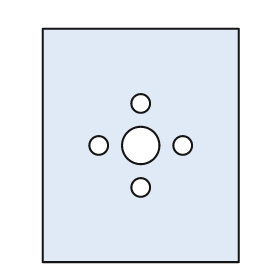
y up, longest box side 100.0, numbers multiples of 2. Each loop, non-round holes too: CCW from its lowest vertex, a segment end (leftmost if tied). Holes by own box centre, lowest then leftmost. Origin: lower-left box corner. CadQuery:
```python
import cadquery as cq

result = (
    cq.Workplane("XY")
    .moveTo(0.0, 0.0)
    .lineTo(84.0, 0.0)
    .lineTo(84.0, 100.0)
    .lineTo(0.0, 100.0)
    .close()
    .moveTo(42.0, 32.0)
    .circle(4.0)
    .moveTo(24.0, 50.0)
    .circle(4.0)
    .moveTo(42.0, 50.0)
    .circle(8.0)
    .moveTo(60.0, 50.0)
    .circle(4.0)
    .moveTo(42.0, 68.0)
    .circle(4.0)
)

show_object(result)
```